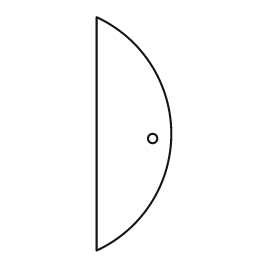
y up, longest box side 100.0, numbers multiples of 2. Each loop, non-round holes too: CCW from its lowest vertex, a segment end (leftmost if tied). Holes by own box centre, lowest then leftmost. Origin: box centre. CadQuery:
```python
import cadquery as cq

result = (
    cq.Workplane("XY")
    .moveTo(-16.0, -50.0)
    .threePointArc((16.0, 0.0), (-16.0, 50.0))
    .close()
    .moveTo(8.0, -2.0)
    .circle(2.0)
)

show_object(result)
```